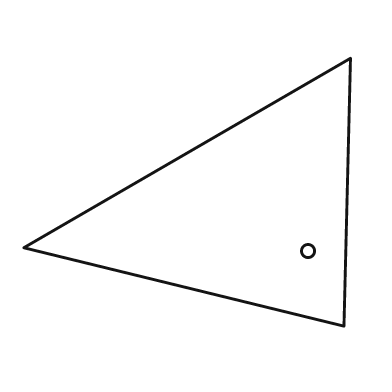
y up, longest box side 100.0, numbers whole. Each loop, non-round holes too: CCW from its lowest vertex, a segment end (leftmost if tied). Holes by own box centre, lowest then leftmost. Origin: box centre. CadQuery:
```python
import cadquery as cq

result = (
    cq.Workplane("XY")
    .moveTo(48.0, -41.0)
    .lineTo(50.0, 41.0)
    .lineTo(-50.0, -17.0)
    .close()
    .moveTo(37.0, -18.0)
    .circle(2.0)
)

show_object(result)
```